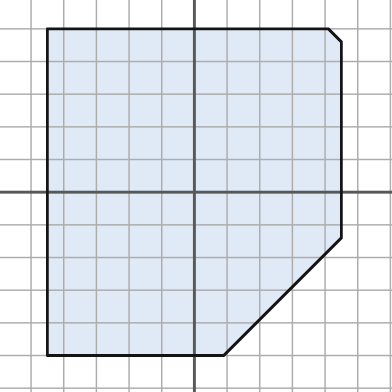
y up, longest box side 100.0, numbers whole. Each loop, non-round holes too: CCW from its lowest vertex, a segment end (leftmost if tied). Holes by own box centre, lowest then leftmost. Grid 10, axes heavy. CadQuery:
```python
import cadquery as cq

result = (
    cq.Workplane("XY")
    .moveTo(-45.0, -50.0)
    .lineTo(9.0, -50.0)
    .lineTo(45.0, -14.0)
    .lineTo(45.0, 46.0)
    .lineTo(41.0, 50.0)
    .lineTo(-45.0, 50.0)
    .close()
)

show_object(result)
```